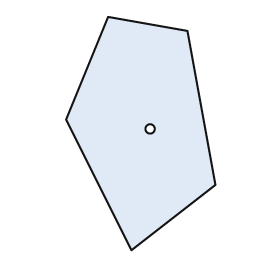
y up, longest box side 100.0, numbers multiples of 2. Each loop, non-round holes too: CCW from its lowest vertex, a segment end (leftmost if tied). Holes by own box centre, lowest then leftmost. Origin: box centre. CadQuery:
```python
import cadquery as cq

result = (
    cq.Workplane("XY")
    .moveTo(-4.0, -50.0)
    .lineTo(32.0, -22.0)
    .lineTo(20.0, 44.0)
    .lineTo(-14.0, 50.0)
    .lineTo(-32.0, 6.0)
    .close()
    .moveTo(4.0, 2.0)
    .circle(2.0)
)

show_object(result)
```